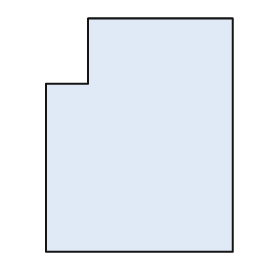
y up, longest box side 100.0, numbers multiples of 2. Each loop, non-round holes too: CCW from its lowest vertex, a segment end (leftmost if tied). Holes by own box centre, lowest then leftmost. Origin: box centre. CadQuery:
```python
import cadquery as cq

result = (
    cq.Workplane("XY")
    .moveTo(-40.0, -50.0)
    .lineTo(40.0, -50.0)
    .lineTo(40.0, 50.0)
    .lineTo(-22.0, 50.0)
    .lineTo(-22.0, 22.0)
    .lineTo(-40.0, 22.0)
    .close()
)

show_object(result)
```